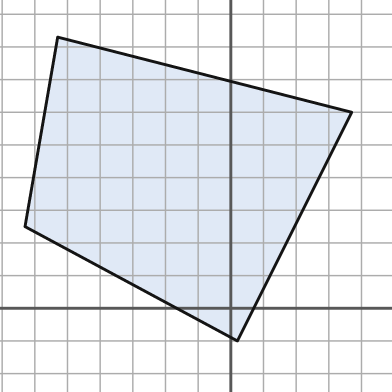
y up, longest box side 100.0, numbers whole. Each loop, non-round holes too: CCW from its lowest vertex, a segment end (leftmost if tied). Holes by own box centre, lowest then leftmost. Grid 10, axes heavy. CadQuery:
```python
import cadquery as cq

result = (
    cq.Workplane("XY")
    .moveTo(2.0, -10.0)
    .lineTo(37.0, 60.0)
    .lineTo(-53.0, 83.0)
    .lineTo(-63.0, 25.0)
    .close()
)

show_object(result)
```